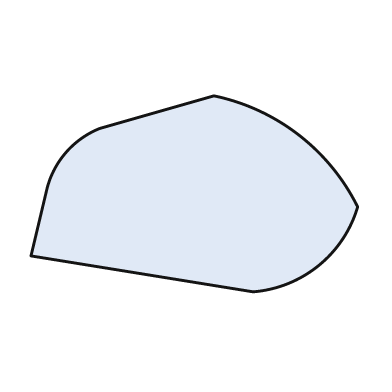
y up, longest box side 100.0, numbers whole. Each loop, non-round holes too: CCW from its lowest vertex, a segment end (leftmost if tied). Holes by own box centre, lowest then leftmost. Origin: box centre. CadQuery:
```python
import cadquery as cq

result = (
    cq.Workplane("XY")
    .moveTo(18.0, -30.0)
    .threePointArc((38.0, -22.0), (50.0, -4.0))
    .threePointArc((32.0, 18.0), (6.0, 30.0))
    .lineTo(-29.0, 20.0)
    .threePointArc((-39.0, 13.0), (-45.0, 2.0))
    .lineTo(-50.0, -19.0)
    .close()
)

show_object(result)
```